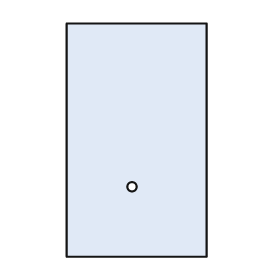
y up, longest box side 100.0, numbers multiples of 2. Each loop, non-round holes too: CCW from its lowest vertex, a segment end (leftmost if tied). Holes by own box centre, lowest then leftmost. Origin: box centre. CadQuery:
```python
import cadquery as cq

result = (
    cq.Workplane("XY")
    .moveTo(-30.0, -50.0)
    .lineTo(30.0, -50.0)
    .lineTo(30.0, 50.0)
    .lineTo(-30.0, 50.0)
    .close()
    .moveTo(-2.0, -20.0)
    .circle(2.0)
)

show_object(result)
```